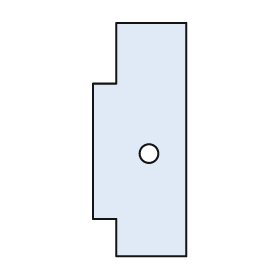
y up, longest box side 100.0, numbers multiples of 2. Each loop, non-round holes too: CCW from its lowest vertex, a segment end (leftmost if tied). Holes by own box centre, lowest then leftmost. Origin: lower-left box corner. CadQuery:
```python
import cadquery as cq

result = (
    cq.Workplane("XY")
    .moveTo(10.0, 0.0)
    .lineTo(40.0, 0.0)
    .lineTo(40.0, 100.0)
    .lineTo(10.0, 100.0)
    .lineTo(10.0, 74.0)
    .lineTo(0.0, 74.0)
    .lineTo(0.0, 16.0)
    .lineTo(10.0, 16.0)
    .close()
    .moveTo(24.0, 44.0)
    .circle(4.0)
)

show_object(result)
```